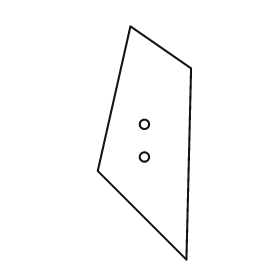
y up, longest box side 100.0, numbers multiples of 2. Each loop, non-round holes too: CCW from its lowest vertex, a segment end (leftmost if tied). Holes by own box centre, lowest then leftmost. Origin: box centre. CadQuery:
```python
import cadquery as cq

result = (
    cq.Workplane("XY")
    .moveTo(18.0, -50.0)
    .lineTo(20.0, 32.0)
    .lineTo(-6.0, 50.0)
    .lineTo(-20.0, -12.0)
    .close()
    .moveTo(0.0, -6.0)
    .circle(2.0)
    .moveTo(0.0, 8.0)
    .circle(2.0)
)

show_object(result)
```